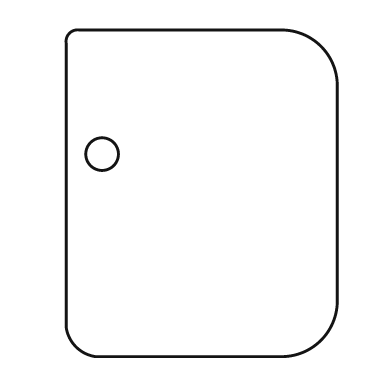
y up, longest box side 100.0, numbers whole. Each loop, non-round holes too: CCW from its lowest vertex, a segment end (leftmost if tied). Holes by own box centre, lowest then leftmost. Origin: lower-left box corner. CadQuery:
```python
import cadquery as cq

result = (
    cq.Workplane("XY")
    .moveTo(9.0, 0.0)
    .lineTo(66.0, 0.0)
    .threePointArc((78.0, 5.0), (83.0, 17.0))
    .lineTo(83.0, 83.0)
    .threePointArc((78.0, 95.0), (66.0, 100.0))
    .lineTo(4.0, 100.0)
    .threePointArc((1.0, 99.0), (0.0, 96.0))
    .lineTo(0.0, 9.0)
    .threePointArc((3.0, 3.0), (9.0, 0.0))
    .close()
    .moveTo(11.0, 62.0)
    .circle(5.0)
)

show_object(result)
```